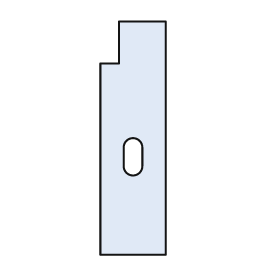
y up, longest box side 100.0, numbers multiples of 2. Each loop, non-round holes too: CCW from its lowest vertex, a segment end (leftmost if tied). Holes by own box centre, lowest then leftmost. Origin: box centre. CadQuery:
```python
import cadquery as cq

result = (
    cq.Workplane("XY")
    .moveTo(-14.0, -50.0)
    .lineTo(14.0, -50.0)
    .lineTo(14.0, 50.0)
    .lineTo(-6.0, 50.0)
    .lineTo(-6.0, 32.0)
    .lineTo(-14.0, 32.0)
    .close()
    .moveTo(-4.0, -12.0)
    .threePointArc((0.0, -16.0), (4.0, -12.0))
    .lineTo(4.0, -4.0)
    .threePointArc((0.0, 0.0), (-4.0, -4.0))
    .close()
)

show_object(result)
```